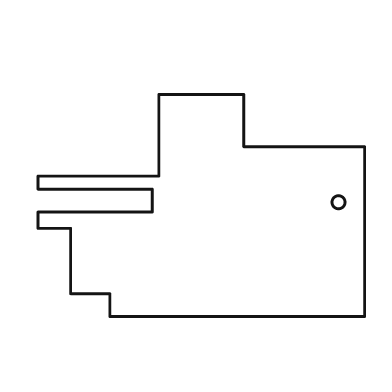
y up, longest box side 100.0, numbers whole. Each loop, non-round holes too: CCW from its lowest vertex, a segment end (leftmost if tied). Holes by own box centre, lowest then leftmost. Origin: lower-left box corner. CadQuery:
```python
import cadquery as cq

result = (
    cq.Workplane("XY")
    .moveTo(22.0, 0.0)
    .lineTo(100.0, 0.0)
    .lineTo(100.0, 52.0)
    .lineTo(63.0, 52.0)
    .lineTo(63.0, 68.0)
    .lineTo(37.0, 68.0)
    .lineTo(37.0, 43.0)
    .lineTo(0.0, 43.0)
    .lineTo(0.0, 39.0)
    .lineTo(35.0, 39.0)
    .lineTo(35.0, 32.0)
    .lineTo(0.0, 32.0)
    .lineTo(0.0, 27.0)
    .lineTo(10.0, 27.0)
    .lineTo(10.0, 7.0)
    .lineTo(22.0, 7.0)
    .close()
    .moveTo(92.0, 35.0)
    .circle(2.0)
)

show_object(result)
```